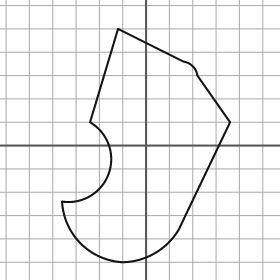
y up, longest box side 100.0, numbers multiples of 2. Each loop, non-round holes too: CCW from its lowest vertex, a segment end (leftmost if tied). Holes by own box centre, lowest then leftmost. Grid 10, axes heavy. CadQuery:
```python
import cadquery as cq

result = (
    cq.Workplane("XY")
    .moveTo(-10.0, -50.0)
    .threePointArc((4.0, -46.0), (14.0, -36.0))
    .lineTo(36.0, 10.0)
    .lineTo(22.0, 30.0)
    .threePointArc((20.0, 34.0), (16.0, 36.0))
    .lineTo(-12.0, 50.0)
    .lineTo(-24.0, 10.0)
    .threePointArc((-16.0, -12.0), (-36.0, -24.0))
    .threePointArc((-28.0, -42.0), (-10.0, -50.0))
    .close()
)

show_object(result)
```